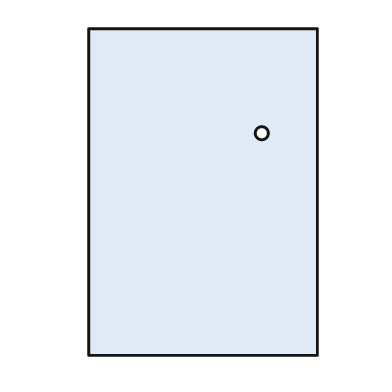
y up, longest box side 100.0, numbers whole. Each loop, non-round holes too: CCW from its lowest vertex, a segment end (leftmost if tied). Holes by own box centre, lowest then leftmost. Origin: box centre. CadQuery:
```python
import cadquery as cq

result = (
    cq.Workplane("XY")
    .moveTo(-35.0, -50.0)
    .lineTo(35.0, -50.0)
    .lineTo(35.0, 50.0)
    .lineTo(-35.0, 50.0)
    .close()
    .moveTo(18.0, 18.0)
    .circle(2.0)
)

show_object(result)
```